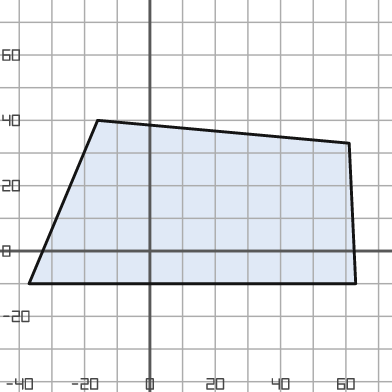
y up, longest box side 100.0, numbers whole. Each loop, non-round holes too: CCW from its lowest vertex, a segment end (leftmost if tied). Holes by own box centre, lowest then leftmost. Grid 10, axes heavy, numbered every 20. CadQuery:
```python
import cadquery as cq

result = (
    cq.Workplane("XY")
    .moveTo(-37.0, -10.0)
    .lineTo(63.0, -10.0)
    .lineTo(61.0, 33.0)
    .lineTo(-16.0, 40.0)
    .close()
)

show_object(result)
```